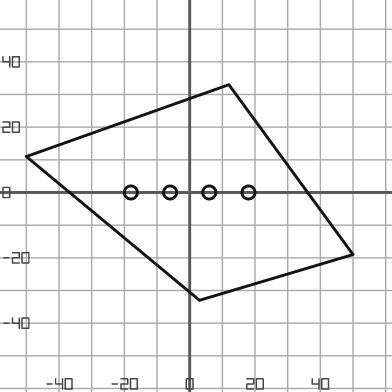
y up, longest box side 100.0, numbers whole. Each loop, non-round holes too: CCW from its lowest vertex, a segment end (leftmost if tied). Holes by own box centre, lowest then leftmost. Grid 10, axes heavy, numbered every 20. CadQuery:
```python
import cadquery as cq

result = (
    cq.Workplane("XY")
    .moveTo(3.0, -33.0)
    .lineTo(50.0, -19.0)
    .lineTo(12.0, 33.0)
    .lineTo(-50.0, 11.0)
    .close()
    .moveTo(-18.0, 0.0)
    .circle(2.0)
    .moveTo(-6.0, 0.0)
    .circle(2.0)
    .moveTo(6.0, 0.0)
    .circle(2.0)
    .moveTo(18.0, 0.0)
    .circle(2.0)
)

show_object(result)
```